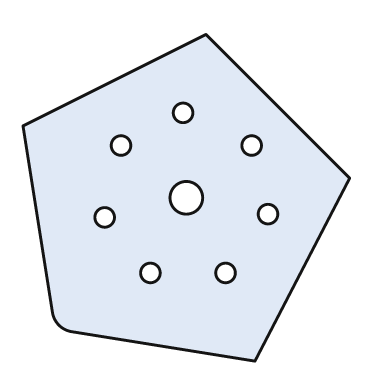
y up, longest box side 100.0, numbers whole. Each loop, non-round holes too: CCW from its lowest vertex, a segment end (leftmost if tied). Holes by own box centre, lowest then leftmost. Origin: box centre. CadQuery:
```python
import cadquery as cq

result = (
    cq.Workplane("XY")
    .moveTo(21.0, -50.0)
    .lineTo(50.0, 6.0)
    .lineTo(6.0, 50.0)
    .lineTo(-50.0, 22.0)
    .lineTo(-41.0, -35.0)
    .threePointArc((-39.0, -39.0), (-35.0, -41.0))
    .close()
    .moveTo(-11.0, -23.0)
    .circle(3.0)
    .moveTo(12.0, -23.0)
    .circle(3.0)
    .moveTo(-25.0, -6.0)
    .circle(3.0)
    .moveTo(25.0, -5.0)
    .circle(3.0)
    .moveTo(0.0, 0.0)
    .circle(5.0)
    .moveTo(-20.0, 16.0)
    .circle(3.0)
    .moveTo(20.0, 16.0)
    .circle(3.0)
    .moveTo(-1.0, 26.0)
    .circle(3.0)
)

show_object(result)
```